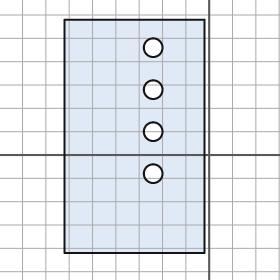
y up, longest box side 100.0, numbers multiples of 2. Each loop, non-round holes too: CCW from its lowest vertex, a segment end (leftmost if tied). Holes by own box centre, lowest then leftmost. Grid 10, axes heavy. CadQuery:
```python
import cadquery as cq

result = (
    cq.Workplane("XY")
    .moveTo(-62.0, -42.0)
    .lineTo(-2.0, -42.0)
    .lineTo(-2.0, 58.0)
    .lineTo(-62.0, 58.0)
    .close()
    .moveTo(-24.0, -8.0)
    .circle(4.0)
    .moveTo(-24.0, 10.0)
    .circle(4.0)
    .moveTo(-24.0, 28.0)
    .circle(4.0)
    .moveTo(-24.0, 46.0)
    .circle(4.0)
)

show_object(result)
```